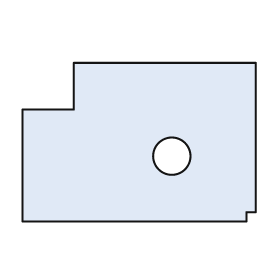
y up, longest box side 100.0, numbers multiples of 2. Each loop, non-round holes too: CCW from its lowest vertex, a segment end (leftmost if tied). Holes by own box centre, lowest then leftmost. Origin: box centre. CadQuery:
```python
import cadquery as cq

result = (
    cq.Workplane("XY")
    .moveTo(-50.0, -34.0)
    .lineTo(46.0, -34.0)
    .lineTo(46.0, -30.0)
    .lineTo(50.0, -30.0)
    .lineTo(50.0, 34.0)
    .lineTo(-28.0, 34.0)
    .lineTo(-28.0, 14.0)
    .lineTo(-50.0, 14.0)
    .close()
    .moveTo(14.0, -6.0)
    .circle(8.0)
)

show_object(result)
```